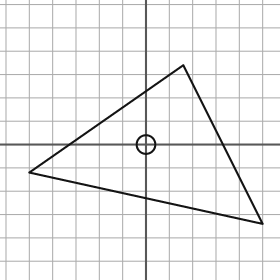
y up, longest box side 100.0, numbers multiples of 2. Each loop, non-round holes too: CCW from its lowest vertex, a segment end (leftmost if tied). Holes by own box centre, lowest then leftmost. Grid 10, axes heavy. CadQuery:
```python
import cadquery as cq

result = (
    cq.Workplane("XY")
    .moveTo(50.0, -34.0)
    .lineTo(16.0, 34.0)
    .lineTo(-50.0, -12.0)
    .close()
    .moveTo(0.0, 0.0)
    .circle(4.0)
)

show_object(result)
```